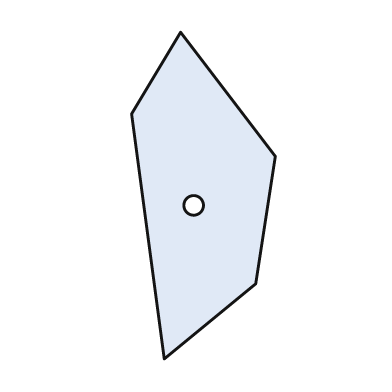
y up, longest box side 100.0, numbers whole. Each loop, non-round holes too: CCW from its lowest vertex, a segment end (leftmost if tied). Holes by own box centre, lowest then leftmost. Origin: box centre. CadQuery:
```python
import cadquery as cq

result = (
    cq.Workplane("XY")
    .moveTo(-12.0, -50.0)
    .lineTo(16.0, -27.0)
    .lineTo(22.0, 12.0)
    .lineTo(-7.0, 50.0)
    .lineTo(-22.0, 25.0)
    .close()
    .moveTo(-3.0, -3.0)
    .circle(3.0)
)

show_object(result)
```